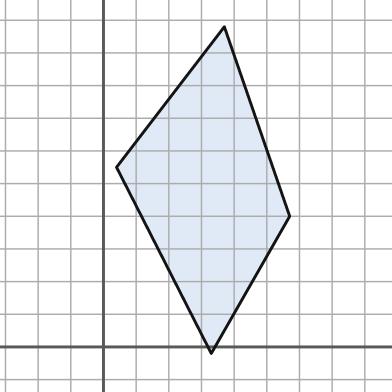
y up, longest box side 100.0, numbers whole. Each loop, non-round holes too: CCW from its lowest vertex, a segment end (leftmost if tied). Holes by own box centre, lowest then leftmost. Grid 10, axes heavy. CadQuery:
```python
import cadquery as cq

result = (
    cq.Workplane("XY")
    .moveTo(33.0, -2.0)
    .lineTo(57.0, 40.0)
    .lineTo(37.0, 98.0)
    .lineTo(4.0, 55.0)
    .close()
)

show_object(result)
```